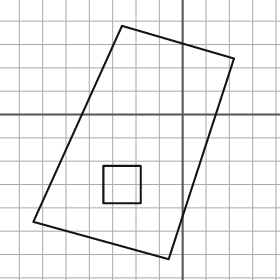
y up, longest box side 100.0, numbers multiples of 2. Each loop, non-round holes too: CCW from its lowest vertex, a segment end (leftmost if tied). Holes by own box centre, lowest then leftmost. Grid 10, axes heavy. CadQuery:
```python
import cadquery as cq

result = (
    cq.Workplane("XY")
    .moveTo(-6.0, -62.0)
    .lineTo(22.0, 24.0)
    .lineTo(-26.0, 38.0)
    .lineTo(-64.0, -46.0)
    .close()
    .moveTo(-34.0, -38.0)
    .lineTo(-18.0, -38.0)
    .lineTo(-18.0, -22.0)
    .lineTo(-34.0, -22.0)
    .close()
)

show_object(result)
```